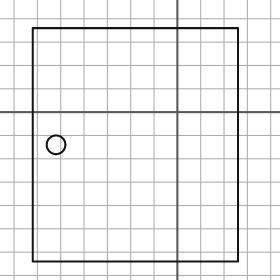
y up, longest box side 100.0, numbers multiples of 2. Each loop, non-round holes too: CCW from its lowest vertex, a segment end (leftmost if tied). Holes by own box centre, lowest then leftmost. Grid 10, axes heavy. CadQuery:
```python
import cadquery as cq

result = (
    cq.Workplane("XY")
    .moveTo(-62.0, -64.0)
    .lineTo(26.0, -64.0)
    .lineTo(26.0, 36.0)
    .lineTo(-62.0, 36.0)
    .close()
    .moveTo(-52.0, -14.0)
    .circle(4.0)
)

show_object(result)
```